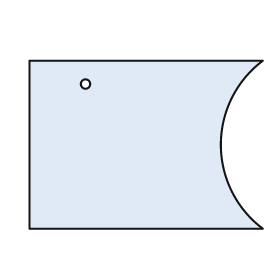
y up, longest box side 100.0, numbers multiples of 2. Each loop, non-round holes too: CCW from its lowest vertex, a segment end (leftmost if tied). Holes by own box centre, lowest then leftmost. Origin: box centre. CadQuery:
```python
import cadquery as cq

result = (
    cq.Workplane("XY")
    .moveTo(-50.0, -36.0)
    .lineTo(50.0, -36.0)
    .threePointArc((32.0, 0.0), (50.0, 36.0))
    .lineTo(-50.0, 36.0)
    .close()
    .moveTo(-26.0, 26.0)
    .circle(2.0)
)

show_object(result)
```